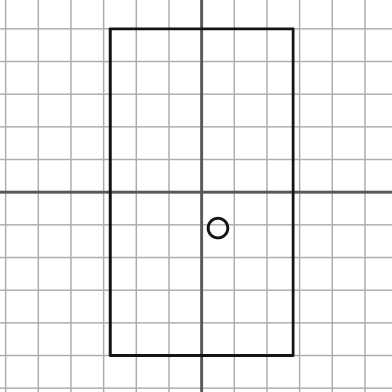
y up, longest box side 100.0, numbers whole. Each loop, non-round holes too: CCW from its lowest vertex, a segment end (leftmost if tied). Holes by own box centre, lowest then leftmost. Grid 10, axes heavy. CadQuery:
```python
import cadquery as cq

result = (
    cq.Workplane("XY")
    .moveTo(-28.0, -50.0)
    .lineTo(28.0, -50.0)
    .lineTo(28.0, 50.0)
    .lineTo(-28.0, 50.0)
    .close()
    .moveTo(5.0, -11.0)
    .circle(3.0)
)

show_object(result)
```